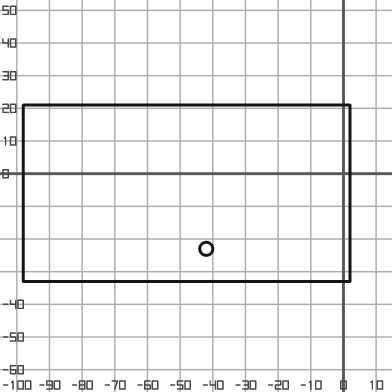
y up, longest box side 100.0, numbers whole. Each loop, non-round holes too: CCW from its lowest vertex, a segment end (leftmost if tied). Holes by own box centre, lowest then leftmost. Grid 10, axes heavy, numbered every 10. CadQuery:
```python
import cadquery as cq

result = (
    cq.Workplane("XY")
    .moveTo(-98.0, -33.0)
    .lineTo(2.0, -33.0)
    .lineTo(2.0, 21.0)
    .lineTo(-98.0, 21.0)
    .close()
    .moveTo(-42.0, -23.0)
    .circle(2.0)
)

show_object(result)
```